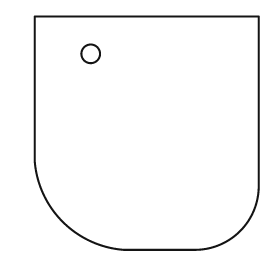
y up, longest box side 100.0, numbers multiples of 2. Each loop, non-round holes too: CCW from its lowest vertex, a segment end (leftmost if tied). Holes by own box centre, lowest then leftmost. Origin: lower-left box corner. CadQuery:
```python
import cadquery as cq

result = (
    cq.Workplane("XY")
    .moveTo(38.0, 0.0)
    .lineTo(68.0, 0.0)
    .threePointArc((88.0, 8.0), (96.0, 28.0))
    .lineTo(96.0, 100.0)
    .lineTo(0.0, 100.0)
    .lineTo(0.0, 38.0)
    .threePointArc((12.0, 12.0), (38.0, 0.0))
    .close()
    .moveTo(24.0, 84.0)
    .circle(4.0)
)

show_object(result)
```